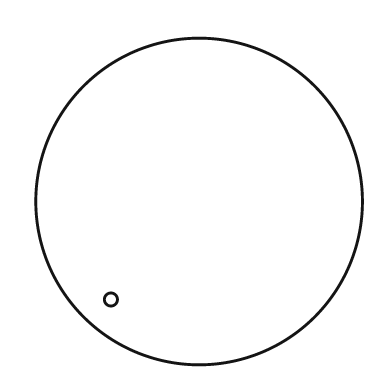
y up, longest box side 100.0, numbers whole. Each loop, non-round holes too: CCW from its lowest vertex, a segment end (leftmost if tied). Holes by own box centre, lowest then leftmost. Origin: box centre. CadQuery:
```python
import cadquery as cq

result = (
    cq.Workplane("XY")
    .moveTo(0.0, 0.0)
    .circle(50.0)
    .moveTo(-27.0, -30.0)
    .circle(2.0)
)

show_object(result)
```